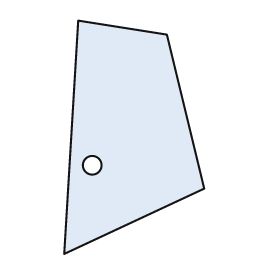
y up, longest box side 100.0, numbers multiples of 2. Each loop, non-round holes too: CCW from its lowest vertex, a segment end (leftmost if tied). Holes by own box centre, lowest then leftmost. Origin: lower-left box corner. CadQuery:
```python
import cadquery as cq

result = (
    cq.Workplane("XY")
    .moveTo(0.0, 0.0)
    .lineTo(60.0, 28.0)
    .lineTo(44.0, 94.0)
    .lineTo(6.0, 100.0)
    .close()
    .moveTo(12.0, 38.0)
    .circle(4.0)
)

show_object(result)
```